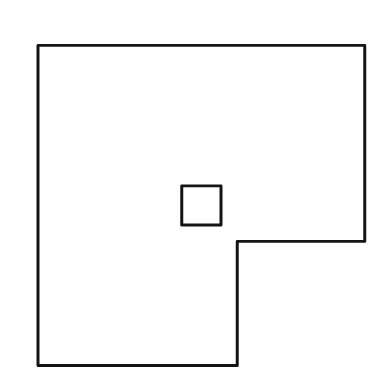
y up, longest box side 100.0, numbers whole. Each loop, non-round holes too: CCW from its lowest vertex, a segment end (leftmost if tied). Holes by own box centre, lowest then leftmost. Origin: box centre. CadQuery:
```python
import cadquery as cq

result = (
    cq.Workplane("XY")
    .moveTo(-50.0, -49.0)
    .lineTo(11.0, -49.0)
    .lineTo(11.0, -11.0)
    .lineTo(50.0, -11.0)
    .lineTo(50.0, 49.0)
    .lineTo(-50.0, 49.0)
    .close()
    .moveTo(-6.0, -6.0)
    .lineTo(6.0, -6.0)
    .lineTo(6.0, 6.0)
    .lineTo(-6.0, 6.0)
    .close()
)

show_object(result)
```